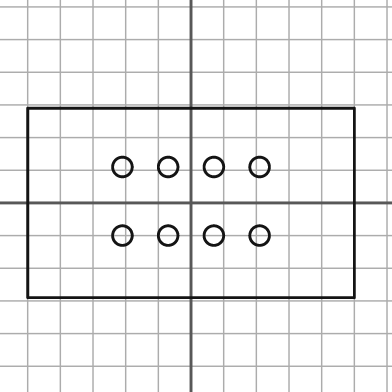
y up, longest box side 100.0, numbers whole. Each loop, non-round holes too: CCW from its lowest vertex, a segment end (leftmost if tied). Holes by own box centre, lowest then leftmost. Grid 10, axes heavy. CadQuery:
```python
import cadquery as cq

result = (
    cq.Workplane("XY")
    .moveTo(-50.0, -29.0)
    .lineTo(50.0, -29.0)
    .lineTo(50.0, 29.0)
    .lineTo(-50.0, 29.0)
    .close()
    .moveTo(-21.0, -10.0)
    .circle(3.0)
    .moveTo(-7.0, -10.0)
    .circle(3.0)
    .moveTo(7.0, -10.0)
    .circle(3.0)
    .moveTo(21.0, -10.0)
    .circle(3.0)
    .moveTo(-21.0, 11.0)
    .circle(3.0)
    .moveTo(-7.0, 11.0)
    .circle(3.0)
    .moveTo(7.0, 11.0)
    .circle(3.0)
    .moveTo(21.0, 11.0)
    .circle(3.0)
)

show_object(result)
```